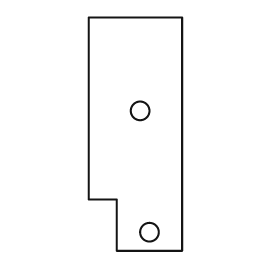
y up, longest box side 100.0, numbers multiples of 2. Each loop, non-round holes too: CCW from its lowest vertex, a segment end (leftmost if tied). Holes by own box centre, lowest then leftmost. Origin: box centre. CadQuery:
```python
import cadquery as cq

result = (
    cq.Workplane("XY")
    .moveTo(-8.0, -50.0)
    .lineTo(20.0, -50.0)
    .lineTo(20.0, 50.0)
    .lineTo(-20.0, 50.0)
    .lineTo(-20.0, -28.0)
    .lineTo(-8.0, -28.0)
    .close()
    .moveTo(6.0, -42.0)
    .circle(4.0)
    .moveTo(2.0, 10.0)
    .circle(4.0)
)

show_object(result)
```